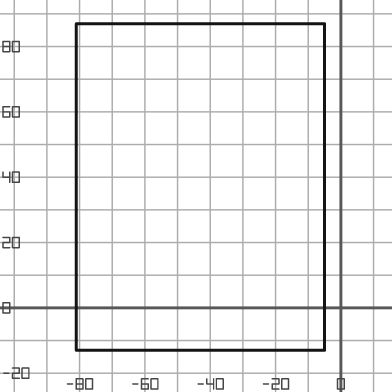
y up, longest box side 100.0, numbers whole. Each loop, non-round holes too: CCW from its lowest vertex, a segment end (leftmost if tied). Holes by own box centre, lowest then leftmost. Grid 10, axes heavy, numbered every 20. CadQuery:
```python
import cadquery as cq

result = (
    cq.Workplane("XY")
    .moveTo(-81.0, -13.0)
    .lineTo(-5.0, -13.0)
    .lineTo(-5.0, 87.0)
    .lineTo(-81.0, 87.0)
    .close()
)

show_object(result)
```